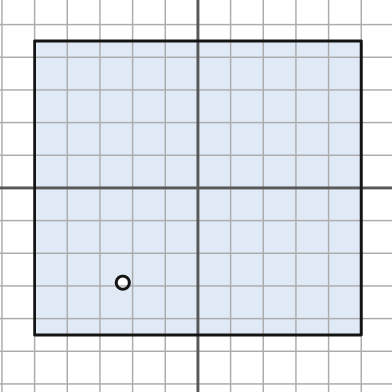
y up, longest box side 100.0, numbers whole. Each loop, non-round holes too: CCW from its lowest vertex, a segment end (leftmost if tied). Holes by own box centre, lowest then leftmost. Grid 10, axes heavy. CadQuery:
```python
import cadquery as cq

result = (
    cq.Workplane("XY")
    .moveTo(-50.0, -45.0)
    .lineTo(50.0, -45.0)
    .lineTo(50.0, 45.0)
    .lineTo(-50.0, 45.0)
    .close()
    .moveTo(-23.0, -29.0)
    .circle(2.0)
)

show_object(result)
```